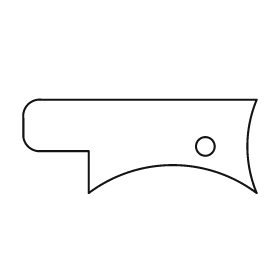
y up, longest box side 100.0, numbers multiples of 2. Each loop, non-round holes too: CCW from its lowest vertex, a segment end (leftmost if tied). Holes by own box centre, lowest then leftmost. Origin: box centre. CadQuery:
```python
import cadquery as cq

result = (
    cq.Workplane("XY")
    .moveTo(-22.0, -20.0)
    .threePointArc((14.0, -8.0), (50.0, -20.0))
    .threePointArc((46.0, 0.0), (50.0, 20.0))
    .lineTo(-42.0, 20.0)
    .threePointArc((-48.0, 18.0), (-50.0, 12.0))
    .lineTo(-50.0, 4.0)
    .threePointArc((-48.0, 0.0), (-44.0, -2.0))
    .lineTo(-22.0, -2.0)
    .close()
    .moveTo(28.0, 0.0)
    .circle(4.0)
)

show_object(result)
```